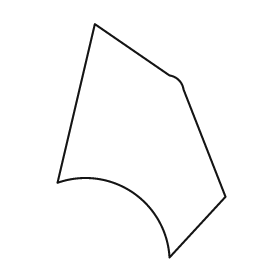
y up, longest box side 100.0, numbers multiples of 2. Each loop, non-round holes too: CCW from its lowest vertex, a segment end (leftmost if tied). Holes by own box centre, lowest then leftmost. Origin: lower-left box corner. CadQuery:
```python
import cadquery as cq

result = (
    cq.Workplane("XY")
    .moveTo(48.0, 0.0)
    .lineTo(72.0, 26.0)
    .lineTo(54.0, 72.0)
    .threePointArc((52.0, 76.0), (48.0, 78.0))
    .lineTo(16.0, 100.0)
    .lineTo(0.0, 32.0)
    .threePointArc((32.0, 28.0), (48.0, 0.0))
    .close()
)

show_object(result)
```